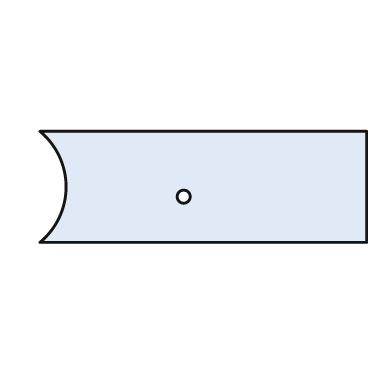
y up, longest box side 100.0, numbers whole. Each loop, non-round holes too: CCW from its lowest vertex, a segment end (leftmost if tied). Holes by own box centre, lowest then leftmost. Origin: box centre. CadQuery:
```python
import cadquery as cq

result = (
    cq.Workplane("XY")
    .moveTo(-50.0, -17.0)
    .lineTo(50.0, -17.0)
    .lineTo(50.0, 17.0)
    .lineTo(-50.0, 17.0)
    .threePointArc((-42.0, 0.0), (-50.0, -17.0))
    .close()
    .moveTo(-6.0, -3.0)
    .circle(2.0)
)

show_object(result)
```